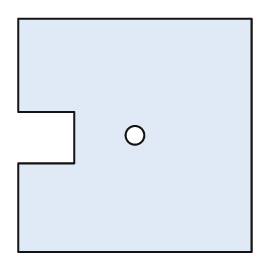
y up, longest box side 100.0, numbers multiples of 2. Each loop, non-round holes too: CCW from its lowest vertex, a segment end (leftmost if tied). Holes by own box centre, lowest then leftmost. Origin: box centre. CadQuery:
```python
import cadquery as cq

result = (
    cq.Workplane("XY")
    .moveTo(-50.0, -50.0)
    .lineTo(50.0, -50.0)
    .lineTo(50.0, 50.0)
    .lineTo(-50.0, 50.0)
    .lineTo(-50.0, 10.0)
    .lineTo(-26.0, 10.0)
    .lineTo(-26.0, -12.0)
    .lineTo(-50.0, -12.0)
    .close()
    .moveTo(0.0, 0.0)
    .circle(4.0)
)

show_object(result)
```